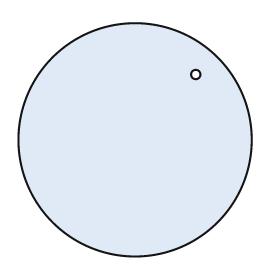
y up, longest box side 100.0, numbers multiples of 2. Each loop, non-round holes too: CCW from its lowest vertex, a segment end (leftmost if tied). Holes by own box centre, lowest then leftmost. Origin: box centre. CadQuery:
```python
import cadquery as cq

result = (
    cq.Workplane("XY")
    .moveTo(0.0, 0.0)
    .circle(50.0)
    .moveTo(26.0, 28.0)
    .circle(2.0)
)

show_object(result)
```